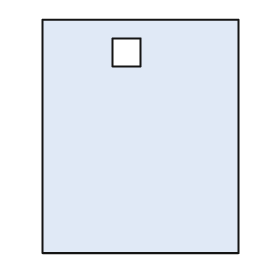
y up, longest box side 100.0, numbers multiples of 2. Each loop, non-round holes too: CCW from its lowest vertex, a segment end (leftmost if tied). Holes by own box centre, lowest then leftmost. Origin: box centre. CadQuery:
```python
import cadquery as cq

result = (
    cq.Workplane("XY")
    .moveTo(-42.0, -50.0)
    .lineTo(42.0, -50.0)
    .lineTo(42.0, 50.0)
    .lineTo(-42.0, 50.0)
    .close()
    .moveTo(-12.0, 30.0)
    .lineTo(0.0, 30.0)
    .lineTo(0.0, 42.0)
    .lineTo(-12.0, 42.0)
    .close()
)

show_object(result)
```